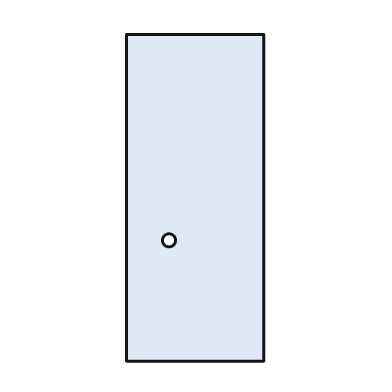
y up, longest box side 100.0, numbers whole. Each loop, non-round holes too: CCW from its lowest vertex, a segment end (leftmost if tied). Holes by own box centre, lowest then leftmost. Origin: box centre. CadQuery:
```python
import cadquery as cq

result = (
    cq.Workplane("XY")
    .moveTo(-21.0, -50.0)
    .lineTo(21.0, -50.0)
    .lineTo(21.0, 50.0)
    .lineTo(-21.0, 50.0)
    .close()
    .moveTo(-8.0, -13.0)
    .circle(2.0)
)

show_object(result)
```